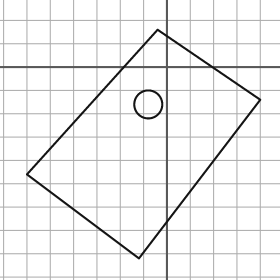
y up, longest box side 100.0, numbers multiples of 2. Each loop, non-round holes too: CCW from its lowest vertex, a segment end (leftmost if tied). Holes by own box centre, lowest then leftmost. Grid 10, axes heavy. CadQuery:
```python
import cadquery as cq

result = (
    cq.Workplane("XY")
    .moveTo(-12.0, -82.0)
    .lineTo(40.0, -14.0)
    .lineTo(-4.0, 16.0)
    .lineTo(-60.0, -46.0)
    .close()
    .moveTo(-8.0, -16.0)
    .circle(6.0)
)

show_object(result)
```